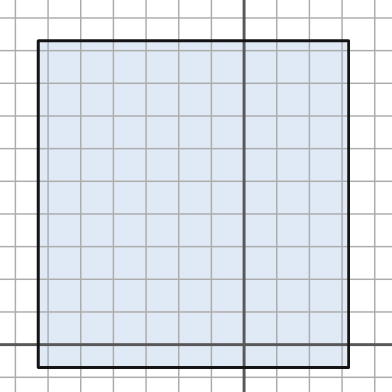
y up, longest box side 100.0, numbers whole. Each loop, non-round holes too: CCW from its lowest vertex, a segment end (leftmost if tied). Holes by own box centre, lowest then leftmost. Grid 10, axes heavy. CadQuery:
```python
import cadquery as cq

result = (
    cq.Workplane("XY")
    .moveTo(-63.0, -7.0)
    .lineTo(32.0, -7.0)
    .lineTo(32.0, 93.0)
    .lineTo(-63.0, 93.0)
    .close()
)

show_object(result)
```